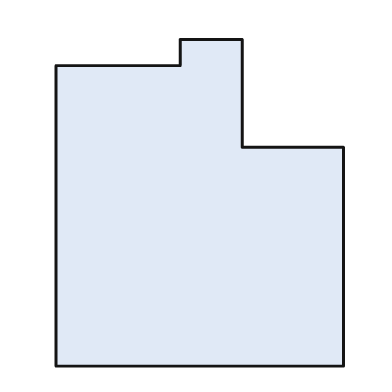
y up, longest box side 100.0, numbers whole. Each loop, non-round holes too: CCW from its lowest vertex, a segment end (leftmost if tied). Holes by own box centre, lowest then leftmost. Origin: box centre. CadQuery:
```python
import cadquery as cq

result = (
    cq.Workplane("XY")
    .moveTo(-44.0, -50.0)
    .lineTo(44.0, -50.0)
    .lineTo(44.0, 17.0)
    .lineTo(13.0, 17.0)
    .lineTo(13.0, 50.0)
    .lineTo(-6.0, 50.0)
    .lineTo(-6.0, 42.0)
    .lineTo(-44.0, 42.0)
    .close()
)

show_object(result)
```